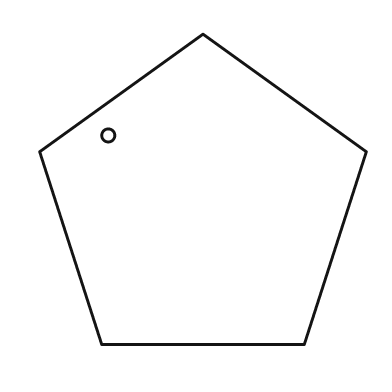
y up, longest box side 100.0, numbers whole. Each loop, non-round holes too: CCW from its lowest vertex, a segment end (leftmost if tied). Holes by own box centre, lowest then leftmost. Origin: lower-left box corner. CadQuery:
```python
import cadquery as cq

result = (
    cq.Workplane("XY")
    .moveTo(19.0, 0.0)
    .lineTo(81.0, 0.0)
    .lineTo(100.0, 59.0)
    .lineTo(50.0, 95.0)
    .lineTo(0.0, 59.0)
    .close()
    .moveTo(21.0, 64.0)
    .circle(2.0)
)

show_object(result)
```